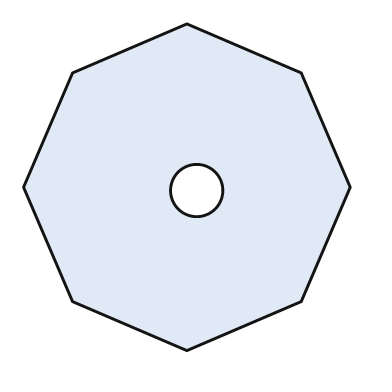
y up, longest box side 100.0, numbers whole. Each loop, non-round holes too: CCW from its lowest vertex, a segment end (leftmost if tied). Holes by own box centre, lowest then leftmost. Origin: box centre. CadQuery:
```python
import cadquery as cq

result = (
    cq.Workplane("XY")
    .moveTo(0.0, -50.0)
    .lineTo(35.0, -35.0)
    .lineTo(50.0, 0.0)
    .lineTo(35.0, 35.0)
    .lineTo(0.0, 50.0)
    .lineTo(-35.0, 35.0)
    .lineTo(-50.0, 0.0)
    .lineTo(-35.0, -35.0)
    .close()
    .moveTo(3.0, -1.0)
    .circle(8.0)
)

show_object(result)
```